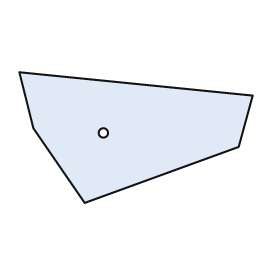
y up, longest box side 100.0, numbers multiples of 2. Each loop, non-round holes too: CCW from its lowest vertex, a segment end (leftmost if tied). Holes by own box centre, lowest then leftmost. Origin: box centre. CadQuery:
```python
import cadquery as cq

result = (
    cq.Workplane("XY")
    .moveTo(-22.0, -28.0)
    .lineTo(44.0, -4.0)
    .lineTo(50.0, 18.0)
    .lineTo(-50.0, 28.0)
    .lineTo(-44.0, 4.0)
    .close()
    .moveTo(-14.0, 2.0)
    .circle(2.0)
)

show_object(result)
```